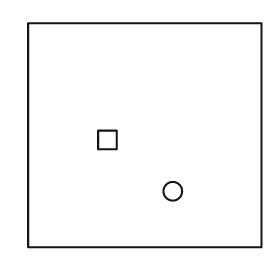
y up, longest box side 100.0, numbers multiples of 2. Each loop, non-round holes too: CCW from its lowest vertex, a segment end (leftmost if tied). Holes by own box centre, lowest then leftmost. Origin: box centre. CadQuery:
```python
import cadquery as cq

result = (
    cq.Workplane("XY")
    .moveTo(-50.0, -48.0)
    .lineTo(50.0, -48.0)
    .lineTo(50.0, 48.0)
    .lineTo(-50.0, 48.0)
    .close()
    .moveTo(12.0, -24.0)
    .circle(4.0)
    .moveTo(-20.0, -6.0)
    .lineTo(-12.0, -6.0)
    .lineTo(-12.0, 2.0)
    .lineTo(-20.0, 2.0)
    .close()
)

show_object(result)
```